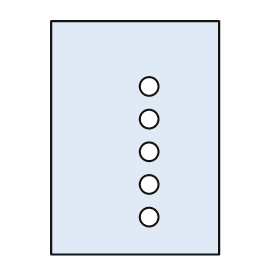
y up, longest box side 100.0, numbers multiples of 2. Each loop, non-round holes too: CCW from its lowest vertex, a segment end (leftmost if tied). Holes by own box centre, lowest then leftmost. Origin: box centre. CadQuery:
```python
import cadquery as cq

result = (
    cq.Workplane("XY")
    .moveTo(-36.0, -50.0)
    .lineTo(36.0, -50.0)
    .lineTo(36.0, 50.0)
    .lineTo(-36.0, 50.0)
    .close()
    .moveTo(6.0, -34.0)
    .circle(4.0)
    .moveTo(6.0, -20.0)
    .circle(4.0)
    .moveTo(6.0, -6.0)
    .circle(4.0)
    .moveTo(6.0, 8.0)
    .circle(4.0)
    .moveTo(6.0, 22.0)
    .circle(4.0)
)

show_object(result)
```